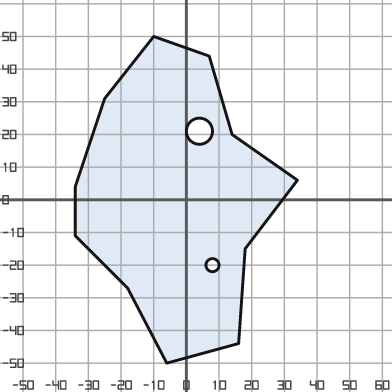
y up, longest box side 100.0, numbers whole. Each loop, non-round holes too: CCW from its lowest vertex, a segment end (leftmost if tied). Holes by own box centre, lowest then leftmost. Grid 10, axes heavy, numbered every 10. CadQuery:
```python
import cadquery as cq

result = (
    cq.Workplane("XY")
    .moveTo(-6.0, -50.0)
    .lineTo(16.0, -44.0)
    .lineTo(18.0, -15.0)
    .lineTo(34.0, 6.0)
    .lineTo(14.0, 20.0)
    .lineTo(7.0, 44.0)
    .lineTo(-10.0, 50.0)
    .lineTo(-25.0, 31.0)
    .lineTo(-34.0, 4.0)
    .lineTo(-34.0, -11.0)
    .lineTo(-18.0, -27.0)
    .close()
    .moveTo(8.0, -20.0)
    .circle(2.0)
    .moveTo(4.0, 21.0)
    .circle(4.0)
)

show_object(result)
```